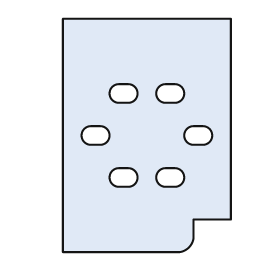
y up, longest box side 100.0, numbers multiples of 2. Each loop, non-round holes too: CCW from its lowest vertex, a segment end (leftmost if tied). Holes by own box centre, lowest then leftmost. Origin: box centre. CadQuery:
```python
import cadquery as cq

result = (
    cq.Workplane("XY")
    .moveTo(-36.0, -50.0)
    .lineTo(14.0, -50.0)
    .threePointArc((18.0, -48.0), (20.0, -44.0))
    .lineTo(20.0, -36.0)
    .lineTo(36.0, -36.0)
    .lineTo(36.0, 50.0)
    .lineTo(-36.0, 50.0)
    .close()
    .moveTo(-12.0, -22.0)
    .lineTo(-8.0, -22.0)
    .threePointArc((-4.0, -18.0), (-8.0, -14.0))
    .lineTo(-12.0, -14.0)
    .threePointArc((-16.0, -18.0), (-12.0, -22.0))
    .close()
    .moveTo(8.0, -22.0)
    .lineTo(12.0, -22.0)
    .threePointArc((16.0, -18.0), (12.0, -14.0))
    .lineTo(8.0, -14.0)
    .threePointArc((4.0, -18.0), (8.0, -22.0))
    .close()
    .moveTo(-24.0, -4.0)
    .lineTo(-20.0, -4.0)
    .threePointArc((-16.0, 0.0), (-20.0, 4.0))
    .lineTo(-24.0, 4.0)
    .threePointArc((-28.0, 0.0), (-24.0, -4.0))
    .close()
    .moveTo(20.0, -4.0)
    .lineTo(24.0, -4.0)
    .threePointArc((28.0, 0.0), (24.0, 4.0))
    .lineTo(20.0, 4.0)
    .threePointArc((16.0, 0.0), (20.0, -4.0))
    .close()
    .moveTo(-12.0, 14.0)
    .lineTo(-8.0, 14.0)
    .threePointArc((-4.0, 18.0), (-8.0, 22.0))
    .lineTo(-12.0, 22.0)
    .threePointArc((-16.0, 18.0), (-12.0, 14.0))
    .close()
    .moveTo(8.0, 14.0)
    .lineTo(12.0, 14.0)
    .threePointArc((16.0, 18.0), (12.0, 22.0))
    .lineTo(8.0, 22.0)
    .threePointArc((4.0, 18.0), (8.0, 14.0))
    .close()
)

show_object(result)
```